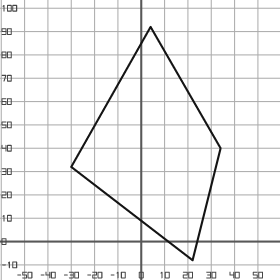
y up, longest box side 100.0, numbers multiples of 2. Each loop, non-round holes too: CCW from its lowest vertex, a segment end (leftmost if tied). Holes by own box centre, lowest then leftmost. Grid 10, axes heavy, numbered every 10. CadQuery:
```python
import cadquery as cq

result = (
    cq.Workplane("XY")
    .moveTo(22.0, -8.0)
    .lineTo(34.0, 40.0)
    .lineTo(4.0, 92.0)
    .lineTo(-30.0, 32.0)
    .close()
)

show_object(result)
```